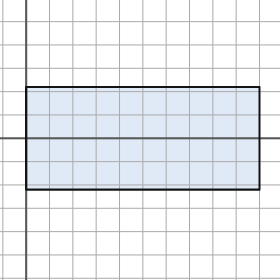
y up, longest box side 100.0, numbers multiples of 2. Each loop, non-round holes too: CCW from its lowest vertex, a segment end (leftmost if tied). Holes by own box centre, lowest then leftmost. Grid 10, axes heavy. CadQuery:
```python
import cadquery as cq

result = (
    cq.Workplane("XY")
    .moveTo(0.0, -22.0)
    .lineTo(100.0, -22.0)
    .lineTo(100.0, 22.0)
    .lineTo(0.0, 22.0)
    .close()
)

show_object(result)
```